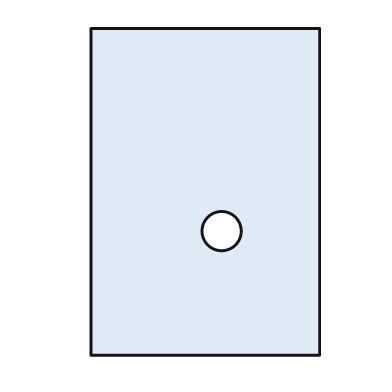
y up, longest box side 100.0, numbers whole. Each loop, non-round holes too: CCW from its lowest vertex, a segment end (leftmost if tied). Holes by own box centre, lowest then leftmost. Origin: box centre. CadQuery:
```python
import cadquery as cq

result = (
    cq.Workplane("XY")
    .moveTo(-35.0, -50.0)
    .lineTo(35.0, -50.0)
    .lineTo(35.0, 50.0)
    .lineTo(-35.0, 50.0)
    .close()
    .moveTo(5.0, -12.0)
    .circle(6.0)
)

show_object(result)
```